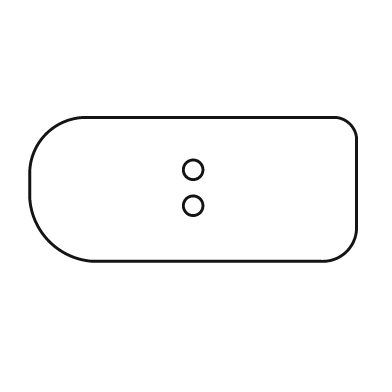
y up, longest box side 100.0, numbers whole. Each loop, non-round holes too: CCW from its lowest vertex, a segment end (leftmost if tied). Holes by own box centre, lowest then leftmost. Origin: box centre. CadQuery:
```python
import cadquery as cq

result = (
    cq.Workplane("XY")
    .moveTo(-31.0, -22.0)
    .lineTo(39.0, -22.0)
    .threePointArc((47.0, -19.0), (50.0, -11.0))
    .lineTo(50.0, 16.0)
    .threePointArc((48.0, 20.0), (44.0, 22.0))
    .lineTo(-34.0, 22.0)
    .threePointArc((-45.0, 17.0), (-50.0, 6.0))
    .lineTo(-50.0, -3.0)
    .threePointArc((-44.0, -16.0), (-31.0, -22.0))
    .close()
    .moveTo(0.0, -5.0)
    .circle(3.0)
    .moveTo(0.0, 6.0)
    .circle(3.0)
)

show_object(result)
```